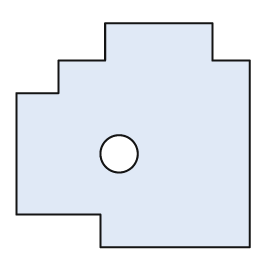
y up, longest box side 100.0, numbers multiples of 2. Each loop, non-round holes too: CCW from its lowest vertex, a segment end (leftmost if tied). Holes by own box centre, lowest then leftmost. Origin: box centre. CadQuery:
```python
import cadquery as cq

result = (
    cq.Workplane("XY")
    .moveTo(-14.0, -48.0)
    .lineTo(50.0, -48.0)
    .lineTo(50.0, 32.0)
    .lineTo(34.0, 32.0)
    .lineTo(34.0, 48.0)
    .lineTo(-12.0, 48.0)
    .lineTo(-12.0, 32.0)
    .lineTo(-32.0, 32.0)
    .lineTo(-32.0, 18.0)
    .lineTo(-50.0, 18.0)
    .lineTo(-50.0, -34.0)
    .lineTo(-14.0, -34.0)
    .close()
    .moveTo(-6.0, -8.0)
    .circle(8.0)
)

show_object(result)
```